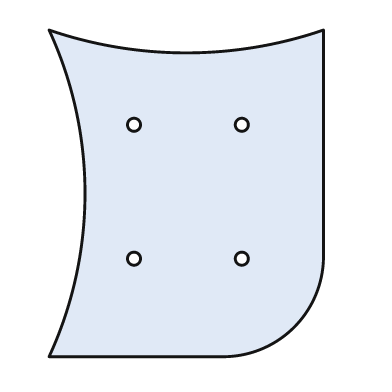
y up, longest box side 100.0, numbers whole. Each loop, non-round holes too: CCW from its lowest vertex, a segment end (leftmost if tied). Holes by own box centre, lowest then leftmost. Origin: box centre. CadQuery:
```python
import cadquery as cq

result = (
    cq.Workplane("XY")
    .moveTo(-42.0, -50.0)
    .lineTo(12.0, -50.0)
    .threePointArc((33.0, -41.0), (42.0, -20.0))
    .lineTo(42.0, 50.0)
    .threePointArc((0.0, 43.0), (-42.0, 50.0))
    .threePointArc((-31.0, 0.0), (-42.0, -50.0))
    .close()
    .moveTo(-16.0, -20.0)
    .circle(2.0)
    .moveTo(17.0, -20.0)
    .circle(2.0)
    .moveTo(-16.0, 21.0)
    .circle(2.0)
    .moveTo(17.0, 21.0)
    .circle(2.0)
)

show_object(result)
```